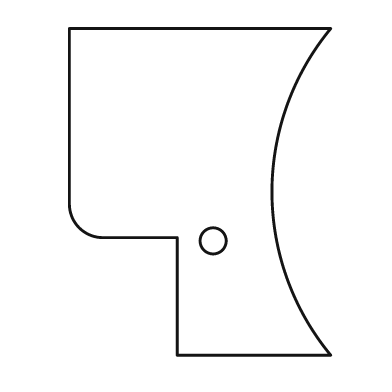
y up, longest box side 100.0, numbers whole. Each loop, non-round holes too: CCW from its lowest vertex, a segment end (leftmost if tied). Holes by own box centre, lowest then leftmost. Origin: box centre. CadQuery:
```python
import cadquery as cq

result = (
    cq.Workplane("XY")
    .moveTo(-7.0, -50.0)
    .lineTo(40.0, -50.0)
    .threePointArc((22.0, 0.0), (40.0, 50.0))
    .lineTo(-40.0, 50.0)
    .lineTo(-40.0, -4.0)
    .threePointArc((-37.0, -11.0), (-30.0, -14.0))
    .lineTo(-7.0, -14.0)
    .close()
    .moveTo(4.0, -15.0)
    .circle(4.0)
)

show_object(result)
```